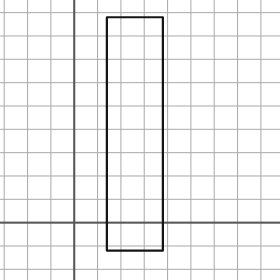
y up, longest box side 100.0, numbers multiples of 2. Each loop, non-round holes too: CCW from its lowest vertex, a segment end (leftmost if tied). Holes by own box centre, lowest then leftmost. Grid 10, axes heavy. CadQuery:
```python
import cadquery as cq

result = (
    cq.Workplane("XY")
    .moveTo(14.0, -12.0)
    .lineTo(38.0, -12.0)
    .lineTo(38.0, 88.0)
    .lineTo(14.0, 88.0)
    .close()
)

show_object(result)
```